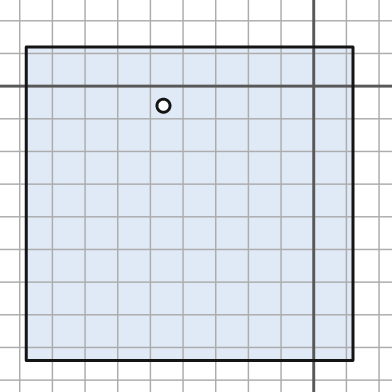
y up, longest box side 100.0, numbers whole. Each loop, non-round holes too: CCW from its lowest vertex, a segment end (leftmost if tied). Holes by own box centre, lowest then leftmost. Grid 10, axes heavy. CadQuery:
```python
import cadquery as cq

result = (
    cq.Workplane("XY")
    .moveTo(-88.0, -84.0)
    .lineTo(12.0, -84.0)
    .lineTo(12.0, 12.0)
    .lineTo(-88.0, 12.0)
    .close()
    .moveTo(-46.0, -6.0)
    .circle(2.0)
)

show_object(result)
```